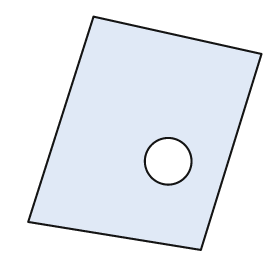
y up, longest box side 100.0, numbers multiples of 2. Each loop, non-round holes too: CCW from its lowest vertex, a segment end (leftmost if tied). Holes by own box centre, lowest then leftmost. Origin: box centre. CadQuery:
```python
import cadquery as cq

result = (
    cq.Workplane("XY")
    .moveTo(24.0, -50.0)
    .lineTo(50.0, 34.0)
    .lineTo(-22.0, 50.0)
    .lineTo(-50.0, -38.0)
    .close()
    .moveTo(10.0, -12.0)
    .circle(10.0)
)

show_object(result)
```